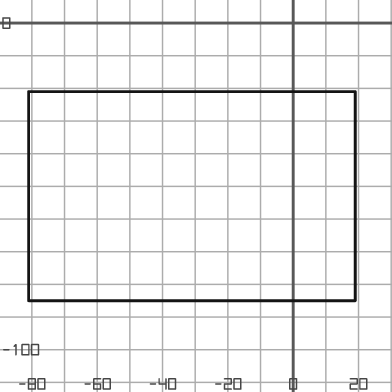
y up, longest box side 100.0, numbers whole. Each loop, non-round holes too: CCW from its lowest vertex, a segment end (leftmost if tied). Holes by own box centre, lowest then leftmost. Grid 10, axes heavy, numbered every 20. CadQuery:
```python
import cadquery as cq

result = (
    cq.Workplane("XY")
    .moveTo(-81.0, -85.0)
    .lineTo(19.0, -85.0)
    .lineTo(19.0, -21.0)
    .lineTo(-81.0, -21.0)
    .close()
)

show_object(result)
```